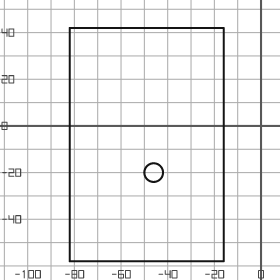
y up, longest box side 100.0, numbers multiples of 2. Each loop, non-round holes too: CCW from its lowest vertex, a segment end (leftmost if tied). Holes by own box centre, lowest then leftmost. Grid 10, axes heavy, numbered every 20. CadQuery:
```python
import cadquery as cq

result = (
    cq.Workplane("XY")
    .moveTo(-82.0, -58.0)
    .lineTo(-16.0, -58.0)
    .lineTo(-16.0, 42.0)
    .lineTo(-82.0, 42.0)
    .close()
    .moveTo(-46.0, -20.0)
    .circle(4.0)
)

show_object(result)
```